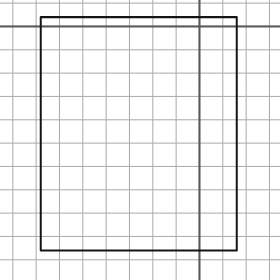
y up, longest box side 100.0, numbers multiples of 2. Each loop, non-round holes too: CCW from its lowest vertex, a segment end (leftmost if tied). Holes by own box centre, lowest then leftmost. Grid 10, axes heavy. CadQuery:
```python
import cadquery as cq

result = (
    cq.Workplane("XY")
    .moveTo(-68.0, -96.0)
    .lineTo(16.0, -96.0)
    .lineTo(16.0, 4.0)
    .lineTo(-68.0, 4.0)
    .close()
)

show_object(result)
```